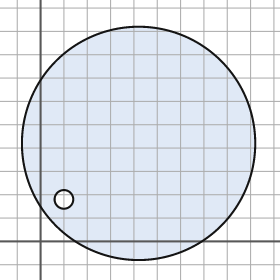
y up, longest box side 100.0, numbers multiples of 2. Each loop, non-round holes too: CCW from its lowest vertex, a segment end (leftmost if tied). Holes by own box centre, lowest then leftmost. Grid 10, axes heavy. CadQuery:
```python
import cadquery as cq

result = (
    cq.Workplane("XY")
    .moveTo(42.0, 42.0)
    .circle(50.0)
    .moveTo(10.0, 18.0)
    .circle(4.0)
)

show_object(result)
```